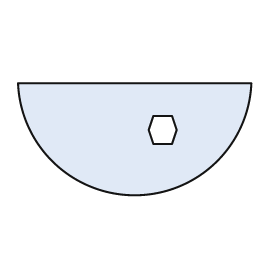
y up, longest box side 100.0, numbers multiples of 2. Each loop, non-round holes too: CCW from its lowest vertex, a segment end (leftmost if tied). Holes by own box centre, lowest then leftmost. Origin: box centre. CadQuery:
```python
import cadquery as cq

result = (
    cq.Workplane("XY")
    .moveTo(-50.0, 24.0)
    .threePointArc((0.0, -24.0), (50.0, 24.0))
    .close()
    .moveTo(8.0, -2.0)
    .lineTo(16.0, -2.0)
    .lineTo(18.0, 4.0)
    .lineTo(16.0, 10.0)
    .lineTo(8.0, 10.0)
    .lineTo(6.0, 4.0)
    .close()
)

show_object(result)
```